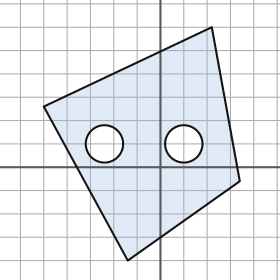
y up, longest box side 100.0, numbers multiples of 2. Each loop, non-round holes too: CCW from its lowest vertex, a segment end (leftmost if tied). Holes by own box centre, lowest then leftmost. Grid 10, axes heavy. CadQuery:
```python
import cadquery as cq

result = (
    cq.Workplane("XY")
    .moveTo(-14.0, -40.0)
    .lineTo(34.0, -6.0)
    .lineTo(22.0, 60.0)
    .lineTo(-50.0, 26.0)
    .close()
    .moveTo(-24.0, 10.0)
    .circle(8.0)
    .moveTo(10.0, 10.0)
    .circle(8.0)
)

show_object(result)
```